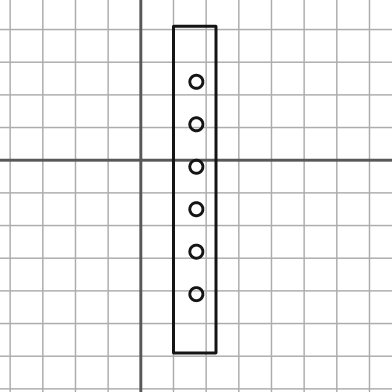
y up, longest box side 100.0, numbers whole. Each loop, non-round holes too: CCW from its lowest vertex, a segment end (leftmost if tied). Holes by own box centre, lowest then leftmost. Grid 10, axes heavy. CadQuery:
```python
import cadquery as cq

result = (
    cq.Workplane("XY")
    .moveTo(10.0, -59.0)
    .lineTo(23.0, -59.0)
    .lineTo(23.0, 41.0)
    .lineTo(10.0, 41.0)
    .close()
    .moveTo(17.0, -41.0)
    .circle(2.0)
    .moveTo(17.0, -28.0)
    .circle(2.0)
    .moveTo(17.0, -15.0)
    .circle(2.0)
    .moveTo(17.0, -2.0)
    .circle(2.0)
    .moveTo(17.0, 11.0)
    .circle(2.0)
    .moveTo(17.0, 24.0)
    .circle(2.0)
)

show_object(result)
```